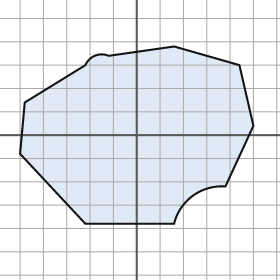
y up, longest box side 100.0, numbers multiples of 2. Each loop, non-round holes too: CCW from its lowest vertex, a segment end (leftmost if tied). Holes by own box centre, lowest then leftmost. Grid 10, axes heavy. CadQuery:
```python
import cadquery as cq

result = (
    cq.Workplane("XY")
    .moveTo(-22.0, -38.0)
    .lineTo(16.0, -38.0)
    .threePointArc((24.0, -26.0), (38.0, -22.0))
    .lineTo(50.0, 4.0)
    .lineTo(44.0, 30.0)
    .lineTo(16.0, 38.0)
    .lineTo(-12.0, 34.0)
    .threePointArc((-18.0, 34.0), (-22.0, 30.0))
    .lineTo(-48.0, 14.0)
    .lineTo(-50.0, -8.0)
    .close()
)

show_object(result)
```